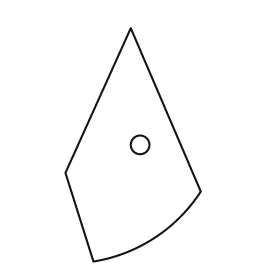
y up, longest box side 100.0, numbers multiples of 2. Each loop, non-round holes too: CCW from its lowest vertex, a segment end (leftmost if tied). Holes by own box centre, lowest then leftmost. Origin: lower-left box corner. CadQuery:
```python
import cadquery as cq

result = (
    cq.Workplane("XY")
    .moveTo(12.0, 0.0)
    .threePointArc((38.0, 10.0), (58.0, 30.0))
    .lineTo(28.0, 100.0)
    .lineTo(0.0, 38.0)
    .close()
    .moveTo(32.0, 50.0)
    .circle(4.0)
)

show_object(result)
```